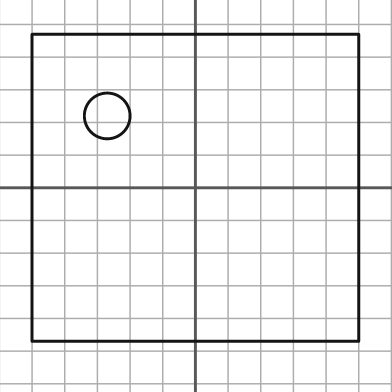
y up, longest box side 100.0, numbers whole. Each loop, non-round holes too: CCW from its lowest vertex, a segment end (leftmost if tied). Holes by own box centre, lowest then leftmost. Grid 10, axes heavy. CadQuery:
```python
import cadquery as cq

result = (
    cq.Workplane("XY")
    .moveTo(-50.0, -47.0)
    .lineTo(50.0, -47.0)
    .lineTo(50.0, 47.0)
    .lineTo(-50.0, 47.0)
    .close()
    .moveTo(-27.0, 22.0)
    .circle(7.0)
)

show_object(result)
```